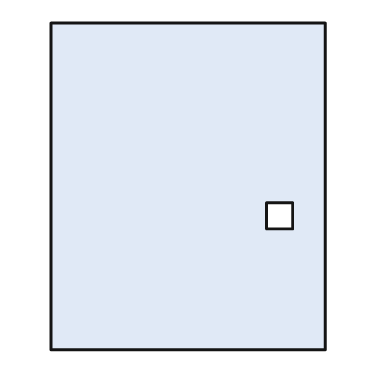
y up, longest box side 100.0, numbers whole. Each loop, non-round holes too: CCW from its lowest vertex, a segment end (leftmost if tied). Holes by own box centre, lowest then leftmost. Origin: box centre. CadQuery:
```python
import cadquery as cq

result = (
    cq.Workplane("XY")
    .moveTo(-42.0, -50.0)
    .lineTo(42.0, -50.0)
    .lineTo(42.0, 50.0)
    .lineTo(-42.0, 50.0)
    .close()
    .moveTo(24.0, -13.0)
    .lineTo(32.0, -13.0)
    .lineTo(32.0, -5.0)
    .lineTo(24.0, -5.0)
    .close()
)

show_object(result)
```